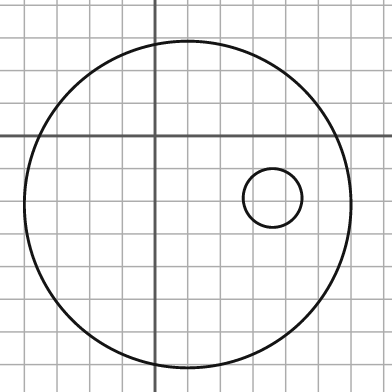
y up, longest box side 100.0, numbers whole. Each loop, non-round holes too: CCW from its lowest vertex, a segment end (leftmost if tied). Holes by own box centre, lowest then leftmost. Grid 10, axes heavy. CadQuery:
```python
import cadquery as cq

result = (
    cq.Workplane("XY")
    .moveTo(10.0, -21.0)
    .circle(50.0)
    .moveTo(36.0, -19.0)
    .circle(9.0)
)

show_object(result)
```